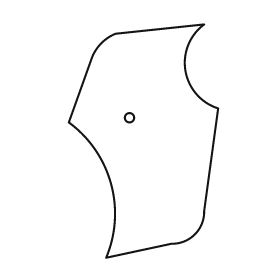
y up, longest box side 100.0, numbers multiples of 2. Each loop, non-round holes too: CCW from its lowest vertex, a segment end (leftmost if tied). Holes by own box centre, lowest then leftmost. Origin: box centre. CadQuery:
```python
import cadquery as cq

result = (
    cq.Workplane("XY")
    .moveTo(-16.0, -50.0)
    .lineTo(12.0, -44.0)
    .threePointArc((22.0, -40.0), (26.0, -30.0))
    .lineTo(32.0, 14.0)
    .threePointArc((18.0, 30.0), (26.0, 50.0))
    .lineTo(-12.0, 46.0)
    .threePointArc((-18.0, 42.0), (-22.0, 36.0))
    .lineTo(-32.0, 8.0)
    .threePointArc((-14.0, -18.0), (-16.0, -50.0))
    .close()
    .moveTo(-6.0, 10.0)
    .circle(2.0)
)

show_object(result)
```